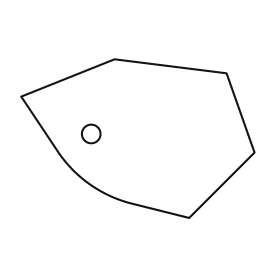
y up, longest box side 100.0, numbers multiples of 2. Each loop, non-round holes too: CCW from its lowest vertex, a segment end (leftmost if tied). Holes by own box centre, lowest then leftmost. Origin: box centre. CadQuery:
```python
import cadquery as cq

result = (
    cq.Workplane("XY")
    .moveTo(22.0, -34.0)
    .lineTo(50.0, -6.0)
    .lineTo(38.0, 28.0)
    .lineTo(-10.0, 34.0)
    .lineTo(-50.0, 18.0)
    .lineTo(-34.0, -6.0)
    .threePointArc((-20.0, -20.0), (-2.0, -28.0))
    .close()
    .moveTo(-20.0, 2.0)
    .circle(4.0)
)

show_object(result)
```